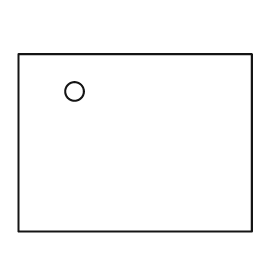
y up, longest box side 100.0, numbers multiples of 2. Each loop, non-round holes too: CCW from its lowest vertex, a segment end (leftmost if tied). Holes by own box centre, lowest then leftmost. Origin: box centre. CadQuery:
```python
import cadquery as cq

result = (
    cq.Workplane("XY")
    .moveTo(-50.0, -38.0)
    .lineTo(50.0, -38.0)
    .lineTo(50.0, 38.0)
    .lineTo(-50.0, 38.0)
    .close()
    .moveTo(-26.0, 22.0)
    .circle(4.0)
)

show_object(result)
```